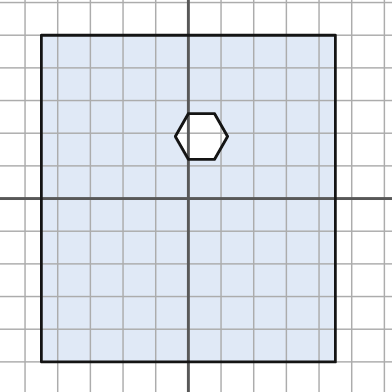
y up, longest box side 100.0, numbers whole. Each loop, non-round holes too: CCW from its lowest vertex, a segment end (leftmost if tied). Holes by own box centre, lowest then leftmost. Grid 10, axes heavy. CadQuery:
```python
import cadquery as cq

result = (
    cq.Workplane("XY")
    .moveTo(-45.0, -50.0)
    .lineTo(45.0, -50.0)
    .lineTo(45.0, 50.0)
    .lineTo(-45.0, 50.0)
    .close()
    .moveTo(0.0, 12.0)
    .lineTo(8.0, 12.0)
    .lineTo(12.0, 19.0)
    .lineTo(8.0, 26.0)
    .lineTo(0.0, 26.0)
    .lineTo(-4.0, 19.0)
    .close()
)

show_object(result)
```